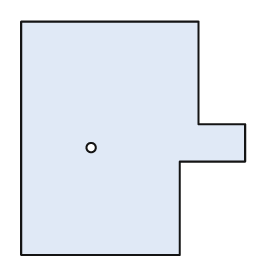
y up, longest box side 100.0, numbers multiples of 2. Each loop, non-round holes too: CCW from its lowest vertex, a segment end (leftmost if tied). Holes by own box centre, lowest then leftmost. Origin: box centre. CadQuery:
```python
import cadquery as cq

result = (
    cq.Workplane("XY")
    .moveTo(-48.0, -50.0)
    .lineTo(20.0, -50.0)
    .lineTo(20.0, -10.0)
    .lineTo(48.0, -10.0)
    .lineTo(48.0, 6.0)
    .lineTo(28.0, 6.0)
    .lineTo(28.0, 50.0)
    .lineTo(-48.0, 50.0)
    .close()
    .moveTo(-18.0, -4.0)
    .circle(2.0)
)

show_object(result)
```